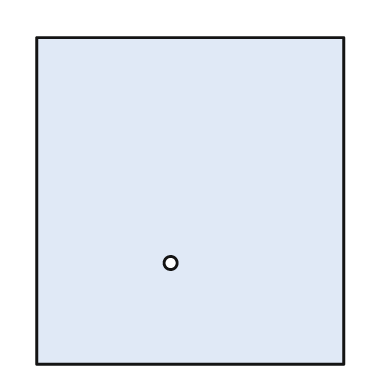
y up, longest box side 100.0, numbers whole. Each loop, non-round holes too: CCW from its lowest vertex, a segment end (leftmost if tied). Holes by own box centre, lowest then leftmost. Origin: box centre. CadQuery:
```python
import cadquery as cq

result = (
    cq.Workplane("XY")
    .moveTo(-47.0, -50.0)
    .lineTo(47.0, -50.0)
    .lineTo(47.0, 50.0)
    .lineTo(-47.0, 50.0)
    .close()
    .moveTo(-6.0, -19.0)
    .circle(2.0)
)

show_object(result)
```